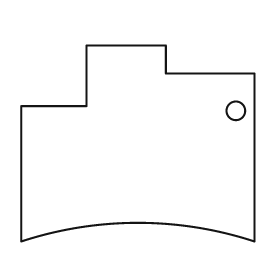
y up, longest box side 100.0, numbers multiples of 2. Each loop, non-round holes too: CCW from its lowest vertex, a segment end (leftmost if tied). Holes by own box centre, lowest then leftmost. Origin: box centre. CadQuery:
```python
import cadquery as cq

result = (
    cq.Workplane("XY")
    .moveTo(-50.0, -42.0)
    .threePointArc((0.0, -34.0), (50.0, -42.0))
    .lineTo(50.0, 30.0)
    .lineTo(12.0, 30.0)
    .lineTo(12.0, 42.0)
    .lineTo(-22.0, 42.0)
    .lineTo(-22.0, 16.0)
    .lineTo(-50.0, 16.0)
    .close()
    .moveTo(42.0, 14.0)
    .circle(4.0)
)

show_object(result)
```